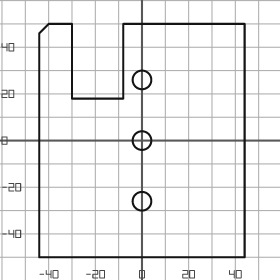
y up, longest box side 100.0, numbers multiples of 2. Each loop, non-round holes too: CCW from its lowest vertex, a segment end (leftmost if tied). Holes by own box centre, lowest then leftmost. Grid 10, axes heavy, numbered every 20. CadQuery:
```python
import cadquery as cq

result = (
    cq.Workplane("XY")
    .moveTo(-44.0, -50.0)
    .lineTo(44.0, -50.0)
    .lineTo(44.0, 50.0)
    .lineTo(-8.0, 50.0)
    .lineTo(-8.0, 18.0)
    .lineTo(-30.0, 18.0)
    .lineTo(-30.0, 50.0)
    .lineTo(-40.0, 50.0)
    .lineTo(-44.0, 46.0)
    .close()
    .moveTo(0.0, -26.0)
    .circle(4.0)
    .moveTo(0.0, 0.0)
    .circle(4.0)
    .moveTo(0.0, 26.0)
    .circle(4.0)
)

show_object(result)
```